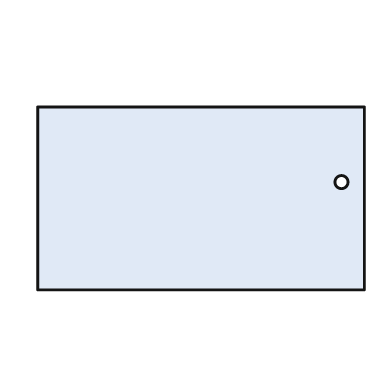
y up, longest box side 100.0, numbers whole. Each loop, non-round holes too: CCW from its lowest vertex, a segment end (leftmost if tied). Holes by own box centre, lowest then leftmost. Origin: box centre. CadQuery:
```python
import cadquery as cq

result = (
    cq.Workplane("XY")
    .moveTo(-50.0, -28.0)
    .lineTo(50.0, -28.0)
    .lineTo(50.0, 28.0)
    .lineTo(-50.0, 28.0)
    .close()
    .moveTo(43.0, 5.0)
    .circle(2.0)
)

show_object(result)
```